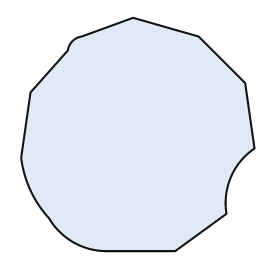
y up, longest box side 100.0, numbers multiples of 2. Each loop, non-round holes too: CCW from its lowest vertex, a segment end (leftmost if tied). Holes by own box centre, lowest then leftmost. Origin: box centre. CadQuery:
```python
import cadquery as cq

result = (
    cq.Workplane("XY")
    .moveTo(-14.0, -50.0)
    .lineTo(16.0, -50.0)
    .lineTo(38.0, -34.0)
    .threePointArc((40.0, -18.0), (50.0, -6.0))
    .lineTo(46.0, 22.0)
    .lineTo(26.0, 42.0)
    .lineTo(-2.0, 50.0)
    .lineTo(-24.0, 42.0)
    .threePointArc((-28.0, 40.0), (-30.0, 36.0))
    .lineTo(-46.0, 18.0)
    .lineTo(-50.0, -10.0)
    .threePointArc((-46.0, -24.0), (-38.0, -36.0))
    .threePointArc((-28.0, -46.0), (-14.0, -50.0))
    .close()
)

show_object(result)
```